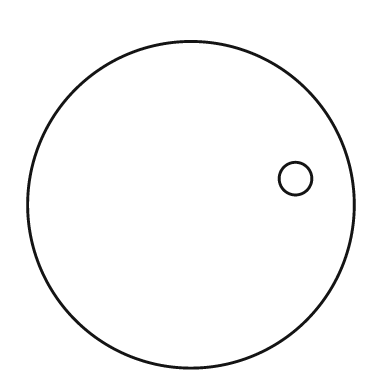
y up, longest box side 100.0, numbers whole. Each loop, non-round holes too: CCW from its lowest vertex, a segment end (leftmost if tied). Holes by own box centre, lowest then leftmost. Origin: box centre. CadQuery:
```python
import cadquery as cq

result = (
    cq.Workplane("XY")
    .moveTo(0.0, 0.0)
    .circle(50.0)
    .moveTo(32.0, 8.0)
    .circle(5.0)
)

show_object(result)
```